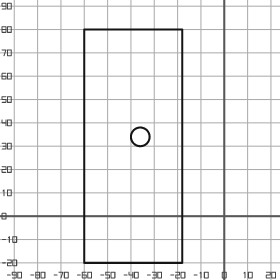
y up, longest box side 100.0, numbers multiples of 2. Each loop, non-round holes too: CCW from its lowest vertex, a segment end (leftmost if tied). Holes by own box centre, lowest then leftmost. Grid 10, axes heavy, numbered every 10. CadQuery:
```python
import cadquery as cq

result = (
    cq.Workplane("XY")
    .moveTo(-60.0, -20.0)
    .lineTo(-18.0, -20.0)
    .lineTo(-18.0, 80.0)
    .lineTo(-60.0, 80.0)
    .close()
    .moveTo(-36.0, 34.0)
    .circle(4.0)
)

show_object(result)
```